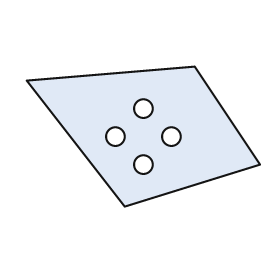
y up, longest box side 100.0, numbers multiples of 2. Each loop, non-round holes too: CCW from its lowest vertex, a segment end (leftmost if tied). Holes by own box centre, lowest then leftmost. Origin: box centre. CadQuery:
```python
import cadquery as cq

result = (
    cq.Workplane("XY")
    .moveTo(-8.0, -30.0)
    .lineTo(50.0, -12.0)
    .lineTo(22.0, 30.0)
    .lineTo(-50.0, 24.0)
    .close()
    .moveTo(0.0, -12.0)
    .circle(4.0)
    .moveTo(-12.0, 0.0)
    .circle(4.0)
    .moveTo(12.0, 0.0)
    .circle(4.0)
    .moveTo(0.0, 12.0)
    .circle(4.0)
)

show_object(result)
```